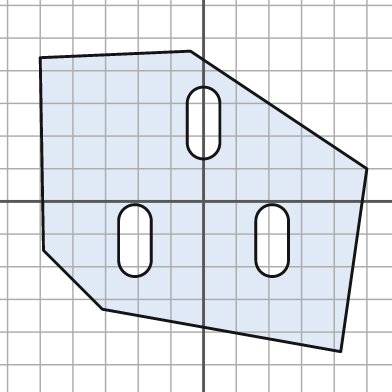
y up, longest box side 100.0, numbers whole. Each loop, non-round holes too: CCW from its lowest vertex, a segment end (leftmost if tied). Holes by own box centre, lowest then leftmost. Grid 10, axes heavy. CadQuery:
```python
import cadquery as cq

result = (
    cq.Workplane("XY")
    .moveTo(42.0, -46.0)
    .lineTo(50.0, 10.0)
    .lineTo(-4.0, 46.0)
    .lineTo(-50.0, 44.0)
    .lineTo(-49.0, -15.0)
    .lineTo(-31.0, -33.0)
    .close()
    .moveTo(-26.0, -18.0)
    .threePointArc((-21.0, -23.0), (-16.0, -18.0))
    .lineTo(-16.0, -6.0)
    .threePointArc((-21.0, -1.0), (-26.0, -6.0))
    .close()
    .moveTo(16.0, -18.0)
    .threePointArc((21.0, -23.0), (26.0, -18.0))
    .lineTo(26.0, -6.0)
    .threePointArc((21.0, -1.0), (16.0, -6.0))
    .close()
    .moveTo(-5.0, 18.0)
    .threePointArc((0.0, 13.0), (5.0, 18.0))
    .lineTo(5.0, 30.0)
    .threePointArc((0.0, 35.0), (-5.0, 30.0))
    .close()
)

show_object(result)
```